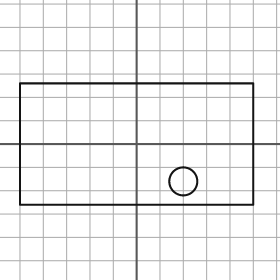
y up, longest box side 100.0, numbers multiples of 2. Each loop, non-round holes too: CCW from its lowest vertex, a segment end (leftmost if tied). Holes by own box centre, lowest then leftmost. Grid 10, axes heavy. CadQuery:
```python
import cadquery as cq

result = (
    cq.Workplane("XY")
    .moveTo(-50.0, -26.0)
    .lineTo(50.0, -26.0)
    .lineTo(50.0, 26.0)
    .lineTo(-50.0, 26.0)
    .close()
    .moveTo(20.0, -16.0)
    .circle(6.0)
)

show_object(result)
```